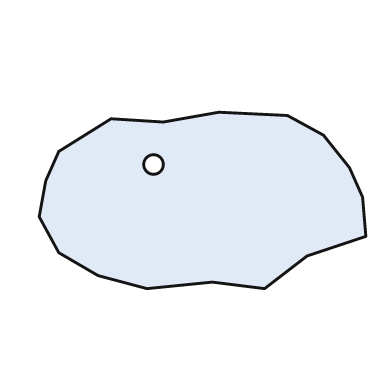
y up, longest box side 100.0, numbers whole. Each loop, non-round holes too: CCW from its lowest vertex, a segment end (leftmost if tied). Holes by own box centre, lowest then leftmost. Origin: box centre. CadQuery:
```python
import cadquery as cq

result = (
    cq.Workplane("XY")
    .moveTo(-17.0, -27.0)
    .lineTo(3.0, -25.0)
    .lineTo(19.0, -27.0)
    .lineTo(32.0, -17.0)
    .lineTo(50.0, -11.0)
    .lineTo(49.0, 1.0)
    .lineTo(45.0, 10.0)
    .lineTo(37.0, 20.0)
    .lineTo(26.0, 26.0)
    .lineTo(5.0, 27.0)
    .lineTo(-12.0, 24.0)
    .lineTo(-28.0, 25.0)
    .lineTo(-44.0, 15.0)
    .lineTo(-48.0, 6.0)
    .lineTo(-50.0, -5.0)
    .lineTo(-44.0, -16.0)
    .lineTo(-32.0, -23.0)
    .close()
    .moveTo(-15.0, 11.0)
    .circle(3.0)
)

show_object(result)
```